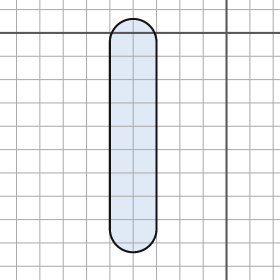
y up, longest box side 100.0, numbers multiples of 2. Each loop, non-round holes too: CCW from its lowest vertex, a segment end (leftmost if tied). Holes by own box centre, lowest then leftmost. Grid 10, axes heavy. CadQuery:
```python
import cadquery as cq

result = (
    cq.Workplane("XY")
    .moveTo(-50.0, -84.0)
    .threePointArc((-40.0, -94.0), (-30.0, -84.0))
    .lineTo(-30.0, -4.0)
    .threePointArc((-40.0, 6.0), (-50.0, -4.0))
    .close()
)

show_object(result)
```